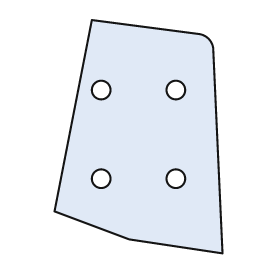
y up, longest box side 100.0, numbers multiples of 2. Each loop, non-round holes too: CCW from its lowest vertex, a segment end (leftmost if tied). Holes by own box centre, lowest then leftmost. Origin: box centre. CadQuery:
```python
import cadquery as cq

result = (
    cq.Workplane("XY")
    .moveTo(36.0, -50.0)
    .lineTo(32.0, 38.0)
    .threePointArc((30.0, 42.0), (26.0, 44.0))
    .lineTo(-20.0, 50.0)
    .lineTo(-36.0, -32.0)
    .lineTo(-4.0, -44.0)
    .close()
    .moveTo(-16.0, -18.0)
    .circle(4.0)
    .moveTo(16.0, -18.0)
    .circle(4.0)
    .moveTo(-16.0, 20.0)
    .circle(4.0)
    .moveTo(16.0, 20.0)
    .circle(4.0)
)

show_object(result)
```